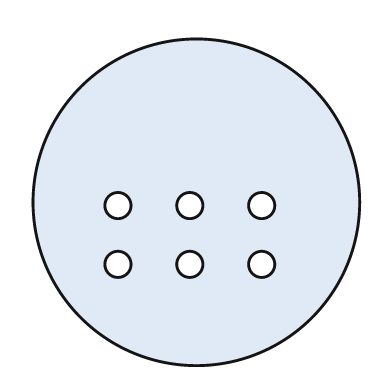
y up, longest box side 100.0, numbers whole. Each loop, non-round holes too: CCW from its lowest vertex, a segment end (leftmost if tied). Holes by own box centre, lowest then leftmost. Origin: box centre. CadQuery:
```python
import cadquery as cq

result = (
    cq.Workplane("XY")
    .moveTo(0.0, 0.0)
    .circle(50.0)
    .moveTo(-24.0, -19.0)
    .circle(4.0)
    .moveTo(-2.0, -19.0)
    .circle(4.0)
    .moveTo(20.0, -19.0)
    .circle(4.0)
    .moveTo(-24.0, -1.0)
    .circle(4.0)
    .moveTo(-2.0, -1.0)
    .circle(4.0)
    .moveTo(20.0, -1.0)
    .circle(4.0)
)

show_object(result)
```